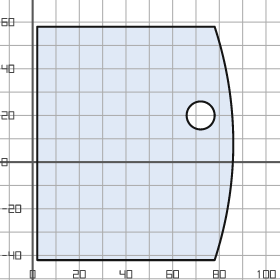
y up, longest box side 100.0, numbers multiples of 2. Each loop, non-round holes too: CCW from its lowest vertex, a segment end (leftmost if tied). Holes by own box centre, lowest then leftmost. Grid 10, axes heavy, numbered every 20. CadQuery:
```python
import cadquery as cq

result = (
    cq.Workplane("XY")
    .moveTo(2.0, -42.0)
    .lineTo(78.0, -42.0)
    .threePointArc((86.0, 8.0), (78.0, 58.0))
    .lineTo(2.0, 58.0)
    .close()
    .moveTo(72.0, 20.0)
    .circle(6.0)
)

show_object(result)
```